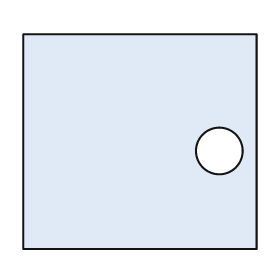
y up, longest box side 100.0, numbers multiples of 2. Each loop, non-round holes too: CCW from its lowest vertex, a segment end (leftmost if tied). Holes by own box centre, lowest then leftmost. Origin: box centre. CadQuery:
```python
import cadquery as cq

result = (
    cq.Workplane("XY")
    .moveTo(-50.0, -46.0)
    .lineTo(50.0, -46.0)
    .lineTo(50.0, 46.0)
    .lineTo(-50.0, 46.0)
    .close()
    .moveTo(34.0, -4.0)
    .circle(10.0)
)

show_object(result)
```